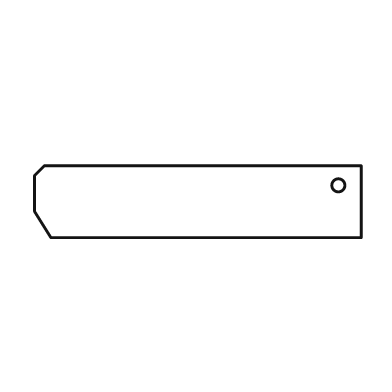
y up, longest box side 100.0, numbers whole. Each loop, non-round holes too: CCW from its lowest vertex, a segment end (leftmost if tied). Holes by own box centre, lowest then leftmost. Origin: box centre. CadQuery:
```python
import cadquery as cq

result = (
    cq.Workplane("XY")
    .moveTo(-45.0, -11.0)
    .lineTo(50.0, -11.0)
    .lineTo(50.0, 11.0)
    .lineTo(-47.0, 11.0)
    .lineTo(-50.0, 8.0)
    .lineTo(-50.0, -3.0)
    .close()
    .moveTo(43.0, 5.0)
    .circle(2.0)
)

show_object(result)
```